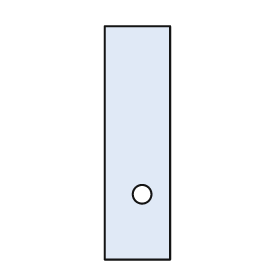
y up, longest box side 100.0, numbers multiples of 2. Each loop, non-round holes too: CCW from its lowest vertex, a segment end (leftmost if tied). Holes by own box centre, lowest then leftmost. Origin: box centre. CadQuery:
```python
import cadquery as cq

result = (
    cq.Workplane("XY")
    .moveTo(-14.0, -50.0)
    .lineTo(14.0, -50.0)
    .lineTo(14.0, 50.0)
    .lineTo(-14.0, 50.0)
    .close()
    .moveTo(2.0, -22.0)
    .circle(4.0)
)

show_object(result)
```